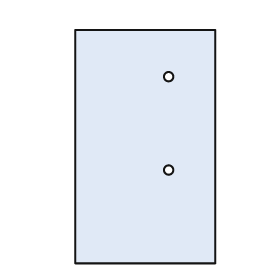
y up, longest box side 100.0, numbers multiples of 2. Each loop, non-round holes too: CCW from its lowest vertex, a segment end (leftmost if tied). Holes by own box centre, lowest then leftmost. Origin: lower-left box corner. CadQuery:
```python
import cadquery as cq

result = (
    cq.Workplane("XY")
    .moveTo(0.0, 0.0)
    .lineTo(60.0, 0.0)
    .lineTo(60.0, 100.0)
    .lineTo(0.0, 100.0)
    .close()
    .moveTo(40.0, 40.0)
    .circle(2.0)
    .moveTo(40.0, 80.0)
    .circle(2.0)
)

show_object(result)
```